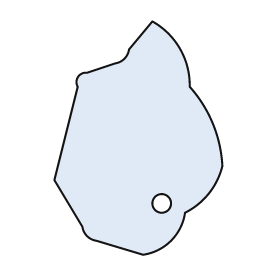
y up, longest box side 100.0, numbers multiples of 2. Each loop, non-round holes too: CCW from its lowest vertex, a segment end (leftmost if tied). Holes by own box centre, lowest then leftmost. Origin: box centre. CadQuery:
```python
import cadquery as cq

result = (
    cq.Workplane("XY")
    .moveTo(2.0, -50.0)
    .threePointArc((14.0, -44.0), (20.0, -32.0))
    .threePointArc((30.0, -24.0), (36.0, -12.0))
    .threePointArc((32.0, 6.0), (22.0, 22.0))
    .threePointArc((18.0, 38.0), (6.0, 50.0))
    .lineTo(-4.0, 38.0)
    .threePointArc((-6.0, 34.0), (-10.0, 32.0))
    .lineTo(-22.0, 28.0)
    .threePointArc((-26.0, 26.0), (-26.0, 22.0))
    .lineTo(-36.0, -18.0)
    .lineTo(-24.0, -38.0)
    .threePointArc((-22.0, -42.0), (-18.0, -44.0))
    .close()
    .moveTo(10.0, -28.0)
    .circle(4.0)
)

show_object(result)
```